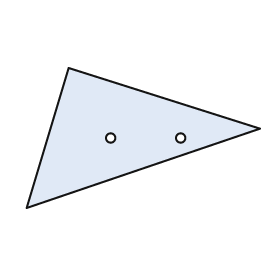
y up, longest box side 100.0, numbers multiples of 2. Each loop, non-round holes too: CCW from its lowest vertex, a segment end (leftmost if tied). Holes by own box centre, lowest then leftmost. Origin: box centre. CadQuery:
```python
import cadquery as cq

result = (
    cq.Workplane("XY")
    .moveTo(-50.0, -30.0)
    .lineTo(50.0, 4.0)
    .lineTo(-32.0, 30.0)
    .close()
    .moveTo(-14.0, 0.0)
    .circle(2.0)
    .moveTo(16.0, 0.0)
    .circle(2.0)
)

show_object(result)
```